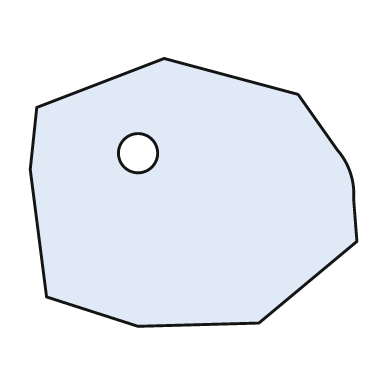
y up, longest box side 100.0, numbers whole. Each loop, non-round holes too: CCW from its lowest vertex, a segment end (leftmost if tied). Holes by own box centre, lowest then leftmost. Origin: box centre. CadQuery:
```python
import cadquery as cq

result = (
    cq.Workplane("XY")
    .moveTo(-17.0, -41.0)
    .lineTo(20.0, -40.0)
    .lineTo(50.0, -15.0)
    .lineTo(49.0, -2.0)
    .threePointArc((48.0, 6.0), (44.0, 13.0))
    .lineTo(32.0, 30.0)
    .lineTo(-9.0, 41.0)
    .lineTo(-48.0, 26.0)
    .lineTo(-50.0, 7.0)
    .lineTo(-45.0, -32.0)
    .close()
    .moveTo(-17.0, 12.0)
    .circle(6.0)
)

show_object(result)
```